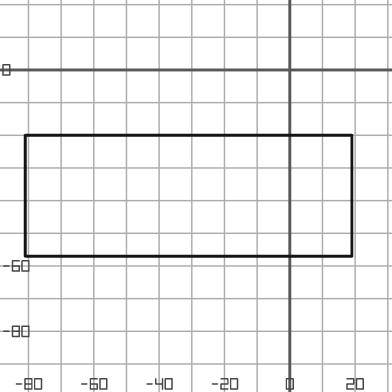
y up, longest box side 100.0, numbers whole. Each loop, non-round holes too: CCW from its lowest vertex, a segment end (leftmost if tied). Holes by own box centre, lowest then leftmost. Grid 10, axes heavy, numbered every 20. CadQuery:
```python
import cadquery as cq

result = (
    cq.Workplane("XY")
    .moveTo(-81.0, -57.0)
    .lineTo(19.0, -57.0)
    .lineTo(19.0, -20.0)
    .lineTo(-81.0, -20.0)
    .close()
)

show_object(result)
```